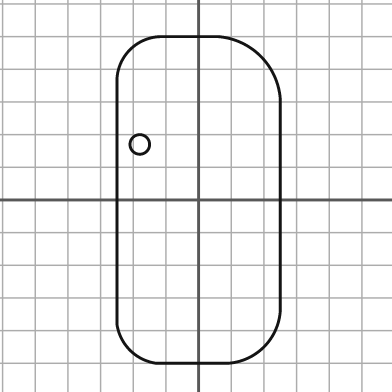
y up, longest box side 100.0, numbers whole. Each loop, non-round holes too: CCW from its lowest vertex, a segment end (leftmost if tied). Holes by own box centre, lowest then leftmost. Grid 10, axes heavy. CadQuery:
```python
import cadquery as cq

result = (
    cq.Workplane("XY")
    .moveTo(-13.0, -50.0)
    .lineTo(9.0, -50.0)
    .threePointArc((20.0, -45.0), (25.0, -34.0))
    .lineTo(25.0, 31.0)
    .threePointArc((19.0, 44.0), (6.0, 50.0))
    .lineTo(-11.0, 50.0)
    .threePointArc((-21.0, 46.0), (-25.0, 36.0))
    .lineTo(-25.0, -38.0)
    .threePointArc((-21.0, -46.0), (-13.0, -50.0))
    .close()
    .moveTo(-18.0, 17.0)
    .circle(3.0)
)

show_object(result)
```